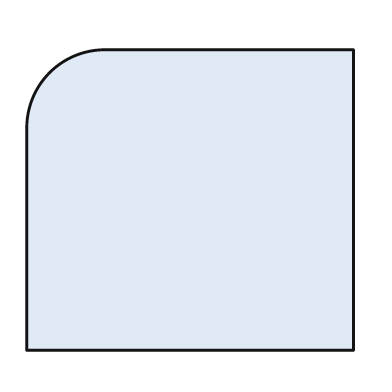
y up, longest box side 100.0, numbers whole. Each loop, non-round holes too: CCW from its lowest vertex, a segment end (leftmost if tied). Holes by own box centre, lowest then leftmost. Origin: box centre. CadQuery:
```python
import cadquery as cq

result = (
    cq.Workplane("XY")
    .moveTo(-50.0, -46.0)
    .lineTo(50.0, -46.0)
    .lineTo(50.0, 46.0)
    .lineTo(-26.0, 46.0)
    .threePointArc((-43.0, 39.0), (-50.0, 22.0))
    .close()
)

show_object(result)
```